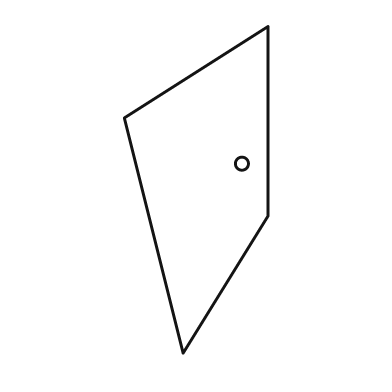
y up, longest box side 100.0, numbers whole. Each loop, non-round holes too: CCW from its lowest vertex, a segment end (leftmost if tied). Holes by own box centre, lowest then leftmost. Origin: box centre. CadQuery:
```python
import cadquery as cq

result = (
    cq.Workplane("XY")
    .moveTo(-4.0, -50.0)
    .lineTo(22.0, -8.0)
    .lineTo(22.0, 50.0)
    .lineTo(-22.0, 22.0)
    .close()
    .moveTo(14.0, 8.0)
    .circle(2.0)
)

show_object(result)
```